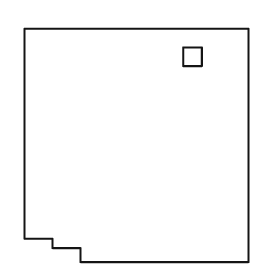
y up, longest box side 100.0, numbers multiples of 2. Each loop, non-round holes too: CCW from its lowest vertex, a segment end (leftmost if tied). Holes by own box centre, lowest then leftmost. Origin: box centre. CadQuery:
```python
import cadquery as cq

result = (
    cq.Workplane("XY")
    .moveTo(-24.0, -50.0)
    .lineTo(48.0, -50.0)
    .lineTo(48.0, 50.0)
    .lineTo(-48.0, 50.0)
    .lineTo(-48.0, -40.0)
    .lineTo(-36.0, -40.0)
    .lineTo(-36.0, -44.0)
    .lineTo(-24.0, -44.0)
    .close()
    .moveTo(20.0, 34.0)
    .lineTo(28.0, 34.0)
    .lineTo(28.0, 42.0)
    .lineTo(20.0, 42.0)
    .close()
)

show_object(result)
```